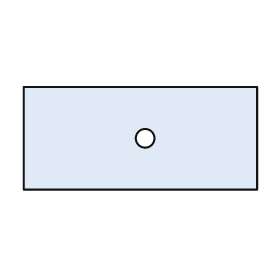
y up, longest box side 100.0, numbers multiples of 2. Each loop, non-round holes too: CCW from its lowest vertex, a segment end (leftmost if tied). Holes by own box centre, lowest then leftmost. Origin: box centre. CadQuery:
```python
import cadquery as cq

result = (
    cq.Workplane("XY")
    .moveTo(-50.0, -22.0)
    .lineTo(50.0, -22.0)
    .lineTo(50.0, 22.0)
    .lineTo(-50.0, 22.0)
    .close()
    .moveTo(2.0, 0.0)
    .circle(4.0)
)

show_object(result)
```